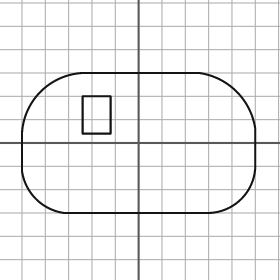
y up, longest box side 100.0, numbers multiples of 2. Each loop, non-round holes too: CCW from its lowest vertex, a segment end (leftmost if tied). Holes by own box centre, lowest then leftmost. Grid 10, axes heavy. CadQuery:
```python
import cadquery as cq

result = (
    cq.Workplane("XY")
    .moveTo(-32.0, -30.0)
    .lineTo(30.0, -30.0)
    .threePointArc((44.0, -24.0), (50.0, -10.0))
    .lineTo(50.0, 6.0)
    .threePointArc((42.0, 22.0), (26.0, 30.0))
    .lineTo(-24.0, 30.0)
    .threePointArc((-42.0, 22.0), (-50.0, 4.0))
    .lineTo(-50.0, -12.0)
    .threePointArc((-44.0, -24.0), (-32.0, -30.0))
    .close()
    .moveTo(-24.0, 4.0)
    .lineTo(-12.0, 4.0)
    .lineTo(-12.0, 20.0)
    .lineTo(-24.0, 20.0)
    .close()
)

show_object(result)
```